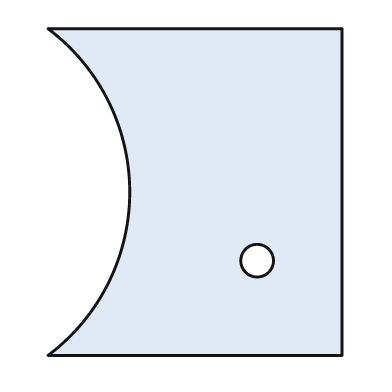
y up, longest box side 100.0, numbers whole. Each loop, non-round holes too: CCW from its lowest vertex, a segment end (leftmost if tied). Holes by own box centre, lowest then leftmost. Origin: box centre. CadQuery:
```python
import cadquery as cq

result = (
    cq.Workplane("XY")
    .moveTo(-45.0, -50.0)
    .lineTo(45.0, -50.0)
    .lineTo(45.0, 50.0)
    .lineTo(-45.0, 50.0)
    .threePointArc((-20.0, 0.0), (-45.0, -50.0))
    .close()
    .moveTo(19.0, -21.0)
    .circle(5.0)
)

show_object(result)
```